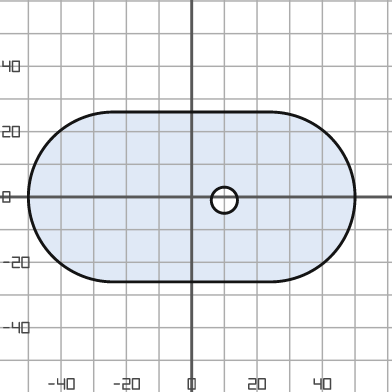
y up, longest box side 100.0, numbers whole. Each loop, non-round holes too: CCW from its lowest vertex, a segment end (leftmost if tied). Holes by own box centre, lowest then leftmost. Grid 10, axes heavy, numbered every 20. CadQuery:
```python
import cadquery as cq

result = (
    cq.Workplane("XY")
    .moveTo(-24.0, -26.0)
    .lineTo(24.0, -26.0)
    .threePointArc((50.0, 0.0), (24.0, 26.0))
    .lineTo(-24.0, 26.0)
    .threePointArc((-50.0, 0.0), (-24.0, -26.0))
    .close()
    .moveTo(10.0, -1.0)
    .circle(4.0)
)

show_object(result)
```